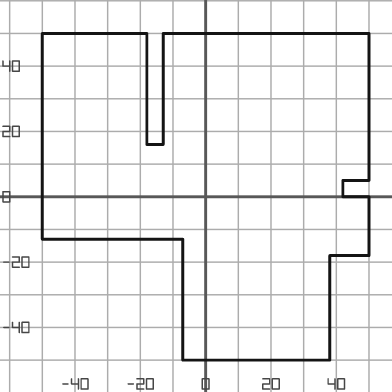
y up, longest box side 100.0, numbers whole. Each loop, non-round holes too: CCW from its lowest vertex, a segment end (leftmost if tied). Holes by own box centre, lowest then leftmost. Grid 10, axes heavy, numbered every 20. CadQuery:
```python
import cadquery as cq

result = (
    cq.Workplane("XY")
    .moveTo(-7.0, -50.0)
    .lineTo(38.0, -50.0)
    .lineTo(38.0, -18.0)
    .lineTo(50.0, -18.0)
    .lineTo(50.0, 0.0)
    .lineTo(42.0, 0.0)
    .lineTo(42.0, 5.0)
    .lineTo(50.0, 5.0)
    .lineTo(50.0, 50.0)
    .lineTo(-13.0, 50.0)
    .lineTo(-13.0, 16.0)
    .lineTo(-18.0, 16.0)
    .lineTo(-18.0, 50.0)
    .lineTo(-50.0, 50.0)
    .lineTo(-50.0, -13.0)
    .lineTo(-7.0, -13.0)
    .close()
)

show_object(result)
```